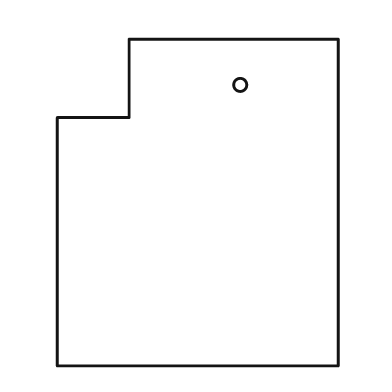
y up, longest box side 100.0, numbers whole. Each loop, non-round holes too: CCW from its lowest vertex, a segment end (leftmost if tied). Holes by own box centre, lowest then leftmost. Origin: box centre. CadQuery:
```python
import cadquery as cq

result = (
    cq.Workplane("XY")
    .moveTo(-43.0, -50.0)
    .lineTo(43.0, -50.0)
    .lineTo(43.0, 50.0)
    .lineTo(-21.0, 50.0)
    .lineTo(-21.0, 26.0)
    .lineTo(-43.0, 26.0)
    .close()
    .moveTo(13.0, 36.0)
    .circle(2.0)
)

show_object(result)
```